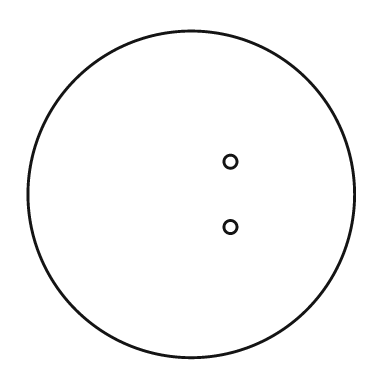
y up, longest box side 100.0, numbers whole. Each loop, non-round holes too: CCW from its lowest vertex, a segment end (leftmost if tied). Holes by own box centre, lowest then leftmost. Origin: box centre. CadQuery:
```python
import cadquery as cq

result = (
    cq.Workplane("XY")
    .moveTo(0.0, 0.0)
    .circle(50.0)
    .moveTo(12.0, -10.0)
    .circle(2.0)
    .moveTo(12.0, 10.0)
    .circle(2.0)
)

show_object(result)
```